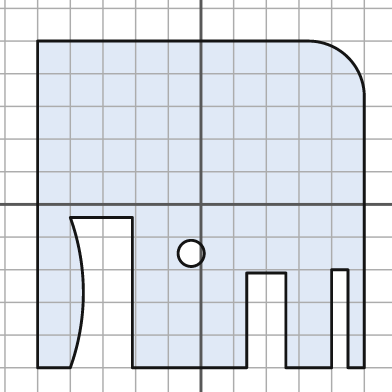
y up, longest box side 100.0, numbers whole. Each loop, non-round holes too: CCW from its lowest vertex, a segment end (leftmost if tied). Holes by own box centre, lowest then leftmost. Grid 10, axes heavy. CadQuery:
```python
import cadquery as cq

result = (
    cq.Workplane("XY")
    .moveTo(-50.0, -50.0)
    .lineTo(-40.0, -50.0)
    .threePointArc((-36.0, -27.0), (-40.0, -4.0))
    .lineTo(-21.0, -4.0)
    .lineTo(-21.0, -50.0)
    .lineTo(14.0, -50.0)
    .lineTo(14.0, -21.0)
    .lineTo(26.0, -21.0)
    .lineTo(26.0, -50.0)
    .lineTo(40.0, -50.0)
    .lineTo(40.0, -20.0)
    .lineTo(45.0, -20.0)
    .lineTo(45.0, -50.0)
    .lineTo(50.0, -50.0)
    .lineTo(50.0, 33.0)
    .threePointArc((45.0, 45.0), (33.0, 50.0))
    .lineTo(-50.0, 50.0)
    .close()
    .moveTo(-3.0, -15.0)
    .circle(4.0)
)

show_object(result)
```